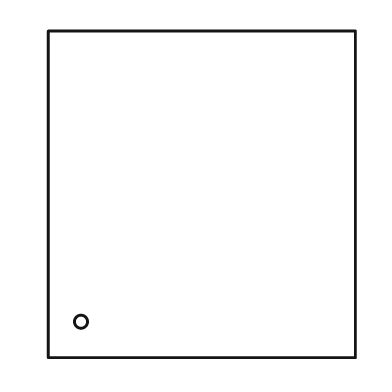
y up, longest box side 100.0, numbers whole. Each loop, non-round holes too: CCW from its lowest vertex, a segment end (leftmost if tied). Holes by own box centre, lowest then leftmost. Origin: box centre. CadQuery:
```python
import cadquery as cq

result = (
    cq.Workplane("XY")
    .moveTo(-47.0, -50.0)
    .lineTo(47.0, -50.0)
    .lineTo(47.0, 50.0)
    .lineTo(-47.0, 50.0)
    .close()
    .moveTo(-37.0, -39.0)
    .circle(2.0)
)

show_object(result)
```